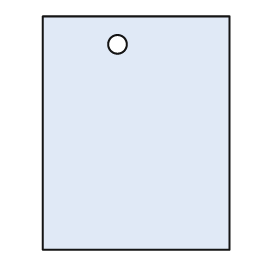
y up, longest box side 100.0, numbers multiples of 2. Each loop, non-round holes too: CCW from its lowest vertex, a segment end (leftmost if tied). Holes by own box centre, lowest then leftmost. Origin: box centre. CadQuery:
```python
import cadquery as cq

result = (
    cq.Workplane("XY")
    .moveTo(-40.0, -50.0)
    .lineTo(40.0, -50.0)
    .lineTo(40.0, 50.0)
    .lineTo(-40.0, 50.0)
    .close()
    .moveTo(-8.0, 38.0)
    .circle(4.0)
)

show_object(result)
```